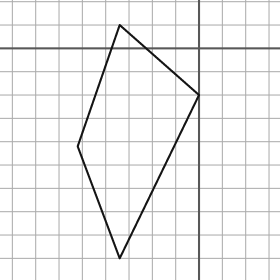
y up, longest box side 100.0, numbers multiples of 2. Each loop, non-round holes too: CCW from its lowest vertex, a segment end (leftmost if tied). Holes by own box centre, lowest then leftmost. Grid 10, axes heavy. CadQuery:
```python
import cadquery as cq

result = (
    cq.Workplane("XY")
    .moveTo(-34.0, -90.0)
    .lineTo(0.0, -20.0)
    .lineTo(-34.0, 10.0)
    .lineTo(-52.0, -42.0)
    .close()
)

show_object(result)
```